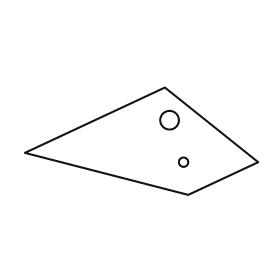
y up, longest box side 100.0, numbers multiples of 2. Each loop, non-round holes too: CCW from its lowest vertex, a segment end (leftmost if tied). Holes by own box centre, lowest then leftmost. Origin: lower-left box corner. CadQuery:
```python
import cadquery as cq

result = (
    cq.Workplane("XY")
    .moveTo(70.0, 0.0)
    .lineTo(100.0, 14.0)
    .lineTo(60.0, 46.0)
    .lineTo(0.0, 18.0)
    .close()
    .moveTo(68.0, 14.0)
    .circle(2.0)
    .moveTo(62.0, 32.0)
    .circle(4.0)
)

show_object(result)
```